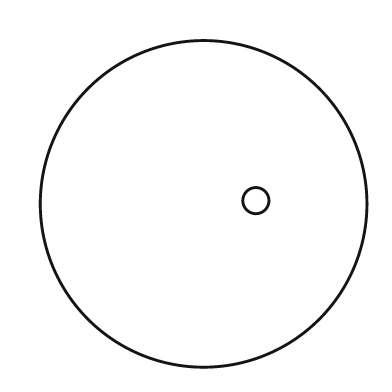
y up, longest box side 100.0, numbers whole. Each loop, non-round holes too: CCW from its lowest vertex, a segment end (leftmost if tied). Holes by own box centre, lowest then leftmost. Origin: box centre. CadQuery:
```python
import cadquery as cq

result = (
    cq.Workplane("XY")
    .moveTo(0.0, 0.0)
    .circle(50.0)
    .moveTo(16.0, 1.0)
    .circle(4.0)
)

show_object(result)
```